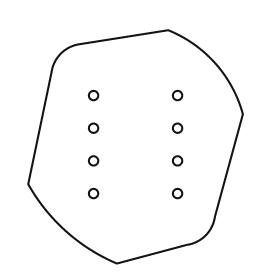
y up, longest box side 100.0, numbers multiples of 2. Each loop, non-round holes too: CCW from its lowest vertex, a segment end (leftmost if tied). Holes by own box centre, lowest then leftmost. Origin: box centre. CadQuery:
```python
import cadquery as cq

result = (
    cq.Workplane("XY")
    .moveTo(-8.0, -50.0)
    .lineTo(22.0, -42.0)
    .threePointArc((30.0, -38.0), (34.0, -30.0))
    .lineTo(46.0, 14.0)
    .threePointArc((34.0, 36.0), (14.0, 50.0))
    .lineTo(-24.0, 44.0)
    .threePointArc((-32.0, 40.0), (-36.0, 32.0))
    .lineTo(-46.0, -16.0)
    .threePointArc((-30.0, -36.0), (-8.0, -50.0))
    .close()
    .moveTo(-18.0, -20.0)
    .circle(2.0)
    .moveTo(18.0, -20.0)
    .circle(2.0)
    .moveTo(-18.0, -6.0)
    .circle(2.0)
    .moveTo(18.0, -6.0)
    .circle(2.0)
    .moveTo(-18.0, 8.0)
    .circle(2.0)
    .moveTo(18.0, 8.0)
    .circle(2.0)
    .moveTo(-18.0, 22.0)
    .circle(2.0)
    .moveTo(18.0, 22.0)
    .circle(2.0)
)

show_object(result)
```